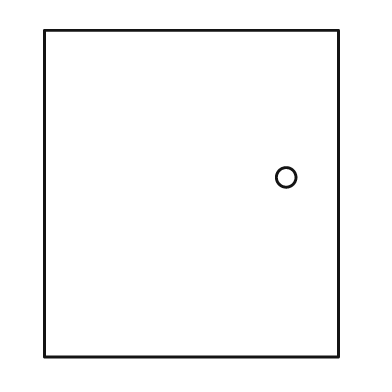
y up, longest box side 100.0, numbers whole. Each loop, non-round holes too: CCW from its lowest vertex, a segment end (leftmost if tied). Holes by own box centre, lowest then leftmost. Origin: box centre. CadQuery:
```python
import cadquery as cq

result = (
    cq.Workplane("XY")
    .moveTo(-45.0, -50.0)
    .lineTo(45.0, -50.0)
    .lineTo(45.0, 50.0)
    .lineTo(-45.0, 50.0)
    .close()
    .moveTo(29.0, 5.0)
    .circle(3.0)
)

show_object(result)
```